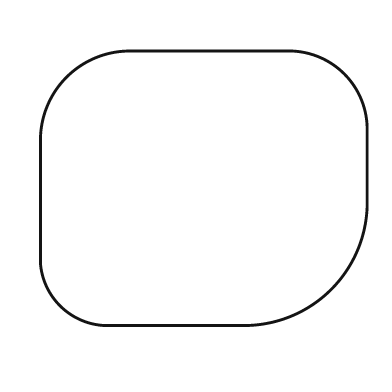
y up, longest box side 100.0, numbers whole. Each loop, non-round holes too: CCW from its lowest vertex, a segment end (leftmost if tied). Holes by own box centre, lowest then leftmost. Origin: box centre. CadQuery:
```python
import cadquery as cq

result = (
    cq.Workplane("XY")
    .moveTo(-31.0, -42.0)
    .lineTo(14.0, -42.0)
    .threePointArc((39.0, -31.0), (50.0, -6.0))
    .lineTo(50.0, 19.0)
    .threePointArc((43.0, 35.0), (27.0, 42.0))
    .lineTo(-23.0, 42.0)
    .threePointArc((-42.0, 34.0), (-50.0, 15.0))
    .lineTo(-50.0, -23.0)
    .threePointArc((-44.0, -36.0), (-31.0, -42.0))
    .close()
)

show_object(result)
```